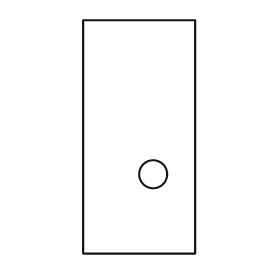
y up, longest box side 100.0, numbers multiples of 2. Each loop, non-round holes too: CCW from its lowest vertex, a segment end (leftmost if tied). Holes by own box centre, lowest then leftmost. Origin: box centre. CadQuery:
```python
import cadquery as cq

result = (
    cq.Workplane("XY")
    .moveTo(-24.0, -50.0)
    .lineTo(24.0, -50.0)
    .lineTo(24.0, 50.0)
    .lineTo(-24.0, 50.0)
    .close()
    .moveTo(6.0, -16.0)
    .circle(6.0)
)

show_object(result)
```